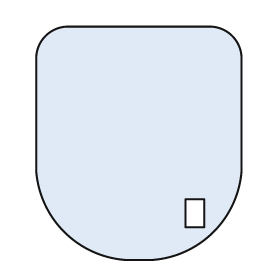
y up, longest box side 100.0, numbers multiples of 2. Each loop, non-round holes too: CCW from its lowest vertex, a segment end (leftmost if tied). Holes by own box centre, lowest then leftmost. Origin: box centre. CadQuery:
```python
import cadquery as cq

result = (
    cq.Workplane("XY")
    .moveTo(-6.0, -50.0)
    .lineTo(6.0, -50.0)
    .threePointArc((32.0, -38.0), (44.0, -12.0))
    .lineTo(44.0, 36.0)
    .threePointArc((40.0, 46.0), (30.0, 50.0))
    .lineTo(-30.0, 50.0)
    .threePointArc((-40.0, 46.0), (-44.0, 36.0))
    .lineTo(-44.0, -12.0)
    .threePointArc((-32.0, -38.0), (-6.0, -50.0))
    .close()
    .moveTo(20.0, -36.0)
    .lineTo(28.0, -36.0)
    .lineTo(28.0, -24.0)
    .lineTo(20.0, -24.0)
    .close()
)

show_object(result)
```